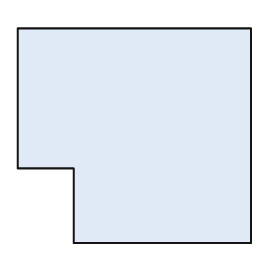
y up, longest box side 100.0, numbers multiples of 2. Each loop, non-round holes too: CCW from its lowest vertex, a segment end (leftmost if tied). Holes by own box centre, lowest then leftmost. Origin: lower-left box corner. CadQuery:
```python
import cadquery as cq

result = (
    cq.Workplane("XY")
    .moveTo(24.0, 0.0)
    .lineTo(100.0, 0.0)
    .lineTo(100.0, 92.0)
    .lineTo(0.0, 92.0)
    .lineTo(0.0, 32.0)
    .lineTo(24.0, 32.0)
    .close()
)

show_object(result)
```